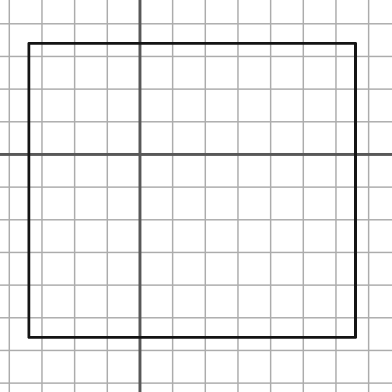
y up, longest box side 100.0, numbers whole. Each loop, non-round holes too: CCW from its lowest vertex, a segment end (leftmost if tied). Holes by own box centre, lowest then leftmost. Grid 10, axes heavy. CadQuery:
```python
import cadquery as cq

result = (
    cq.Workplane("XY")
    .moveTo(-34.0, -56.0)
    .lineTo(66.0, -56.0)
    .lineTo(66.0, 34.0)
    .lineTo(-34.0, 34.0)
    .close()
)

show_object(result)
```